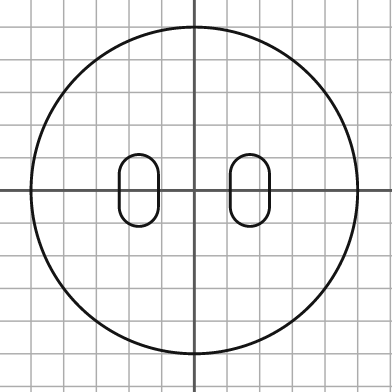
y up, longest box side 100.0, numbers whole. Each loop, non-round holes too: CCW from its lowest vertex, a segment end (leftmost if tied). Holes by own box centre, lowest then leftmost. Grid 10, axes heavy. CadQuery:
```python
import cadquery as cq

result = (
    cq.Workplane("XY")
    .moveTo(0.0, 0.0)
    .circle(50.0)
    .moveTo(-23.0, -5.0)
    .threePointArc((-17.0, -11.0), (-11.0, -5.0))
    .lineTo(-11.0, 5.0)
    .threePointArc((-17.0, 11.0), (-23.0, 5.0))
    .close()
    .moveTo(11.0, -5.0)
    .threePointArc((17.0, -11.0), (23.0, -5.0))
    .lineTo(23.0, 5.0)
    .threePointArc((17.0, 11.0), (11.0, 5.0))
    .close()
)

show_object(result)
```